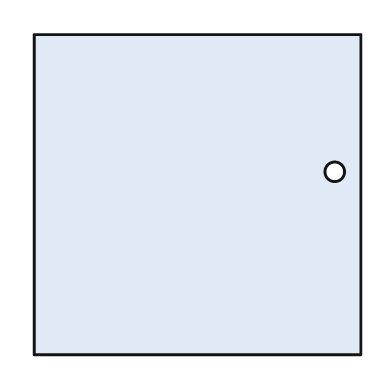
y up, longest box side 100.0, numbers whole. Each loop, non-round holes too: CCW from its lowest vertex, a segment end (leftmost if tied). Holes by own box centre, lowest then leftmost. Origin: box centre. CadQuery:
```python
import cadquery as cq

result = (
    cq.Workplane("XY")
    .moveTo(-50.0, -49.0)
    .lineTo(50.0, -49.0)
    .lineTo(50.0, 49.0)
    .lineTo(-50.0, 49.0)
    .close()
    .moveTo(42.0, 7.0)
    .circle(3.0)
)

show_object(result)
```